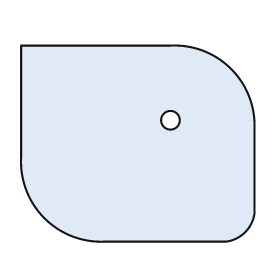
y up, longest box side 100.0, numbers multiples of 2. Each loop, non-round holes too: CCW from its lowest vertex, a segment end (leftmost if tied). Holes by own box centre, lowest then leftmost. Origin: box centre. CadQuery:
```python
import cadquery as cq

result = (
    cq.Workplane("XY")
    .moveTo(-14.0, -42.0)
    .lineTo(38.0, -42.0)
    .threePointArc((46.0, -38.0), (50.0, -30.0))
    .lineTo(50.0, 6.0)
    .threePointArc((40.0, 32.0), (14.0, 42.0))
    .lineTo(-50.0, 42.0)
    .lineTo(-50.0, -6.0)
    .threePointArc((-40.0, -32.0), (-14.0, -42.0))
    .close()
    .moveTo(14.0, 10.0)
    .circle(4.0)
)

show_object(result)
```